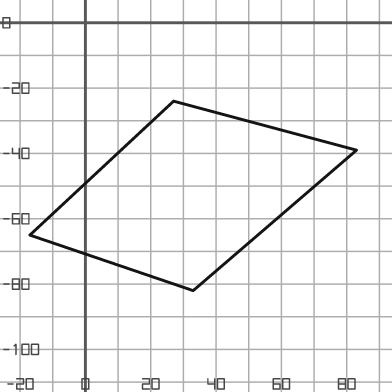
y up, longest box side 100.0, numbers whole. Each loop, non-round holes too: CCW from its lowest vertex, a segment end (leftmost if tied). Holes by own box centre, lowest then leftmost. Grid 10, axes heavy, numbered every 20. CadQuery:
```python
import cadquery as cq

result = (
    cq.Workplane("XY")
    .moveTo(33.0, -82.0)
    .lineTo(83.0, -39.0)
    .lineTo(27.0, -24.0)
    .lineTo(-17.0, -65.0)
    .close()
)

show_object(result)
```